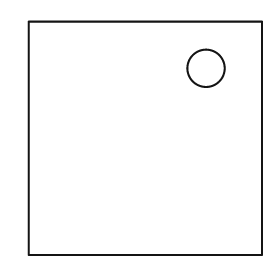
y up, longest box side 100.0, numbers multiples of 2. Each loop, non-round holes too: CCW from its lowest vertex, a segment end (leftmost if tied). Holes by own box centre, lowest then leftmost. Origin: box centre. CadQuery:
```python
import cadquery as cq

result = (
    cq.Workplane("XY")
    .moveTo(-50.0, -50.0)
    .lineTo(50.0, -50.0)
    .lineTo(50.0, 50.0)
    .lineTo(-50.0, 50.0)
    .close()
    .moveTo(26.0, 30.0)
    .circle(8.0)
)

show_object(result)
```